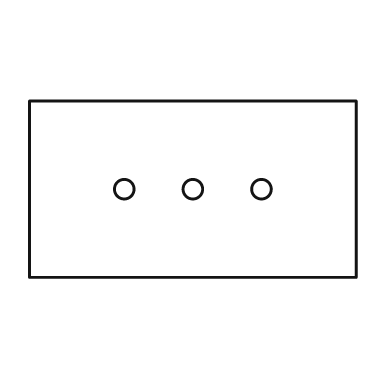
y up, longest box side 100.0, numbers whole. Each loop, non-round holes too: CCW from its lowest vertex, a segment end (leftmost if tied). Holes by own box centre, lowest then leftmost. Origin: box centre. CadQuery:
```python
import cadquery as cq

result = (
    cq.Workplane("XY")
    .moveTo(-50.0, -27.0)
    .lineTo(50.0, -27.0)
    .lineTo(50.0, 27.0)
    .lineTo(-50.0, 27.0)
    .close()
    .moveTo(-21.0, 0.0)
    .circle(3.0)
    .moveTo(0.0, 0.0)
    .circle(3.0)
    .moveTo(21.0, 0.0)
    .circle(3.0)
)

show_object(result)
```